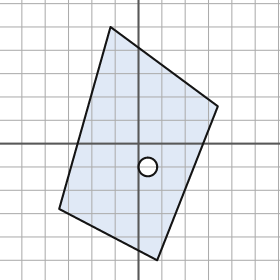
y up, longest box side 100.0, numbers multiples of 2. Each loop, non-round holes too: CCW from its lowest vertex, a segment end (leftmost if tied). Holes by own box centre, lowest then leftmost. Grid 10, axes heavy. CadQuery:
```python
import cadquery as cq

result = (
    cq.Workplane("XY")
    .moveTo(8.0, -50.0)
    .lineTo(34.0, 16.0)
    .lineTo(-12.0, 50.0)
    .lineTo(-34.0, -28.0)
    .close()
    .moveTo(4.0, -10.0)
    .circle(4.0)
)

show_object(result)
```